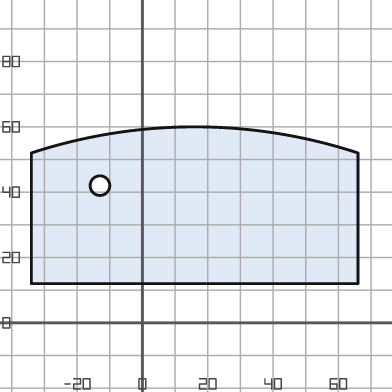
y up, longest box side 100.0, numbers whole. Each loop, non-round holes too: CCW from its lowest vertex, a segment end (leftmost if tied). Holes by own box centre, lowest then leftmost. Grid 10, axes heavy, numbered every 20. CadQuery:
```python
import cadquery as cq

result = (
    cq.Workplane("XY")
    .moveTo(-34.0, 12.0)
    .lineTo(66.0, 12.0)
    .lineTo(66.0, 52.0)
    .threePointArc((16.0, 60.0), (-34.0, 52.0))
    .close()
    .moveTo(-13.0, 42.0)
    .circle(3.0)
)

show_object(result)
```